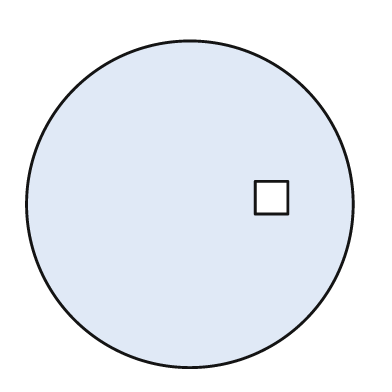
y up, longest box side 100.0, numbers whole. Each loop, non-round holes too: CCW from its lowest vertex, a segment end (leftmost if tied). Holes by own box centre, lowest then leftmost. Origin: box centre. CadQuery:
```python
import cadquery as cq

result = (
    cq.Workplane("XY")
    .moveTo(0.0, 0.0)
    .circle(50.0)
    .moveTo(20.0, -3.0)
    .lineTo(30.0, -3.0)
    .lineTo(30.0, 7.0)
    .lineTo(20.0, 7.0)
    .close()
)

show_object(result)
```